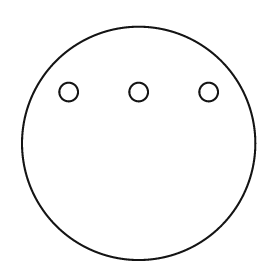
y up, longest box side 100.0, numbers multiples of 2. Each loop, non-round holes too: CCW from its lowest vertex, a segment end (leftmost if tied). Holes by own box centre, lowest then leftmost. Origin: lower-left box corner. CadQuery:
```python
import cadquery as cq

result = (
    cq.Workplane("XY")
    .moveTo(50.0, 50.0)
    .circle(50.0)
    .moveTo(20.0, 72.0)
    .circle(4.0)
    .moveTo(50.0, 72.0)
    .circle(4.0)
    .moveTo(80.0, 72.0)
    .circle(4.0)
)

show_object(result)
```